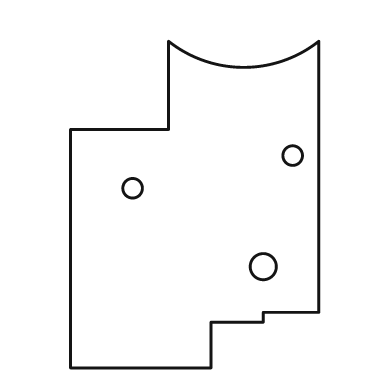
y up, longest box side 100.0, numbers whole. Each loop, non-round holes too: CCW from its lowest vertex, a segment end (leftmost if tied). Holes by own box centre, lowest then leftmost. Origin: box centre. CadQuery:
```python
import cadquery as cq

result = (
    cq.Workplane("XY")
    .moveTo(-38.0, -50.0)
    .lineTo(5.0, -50.0)
    .lineTo(5.0, -36.0)
    .lineTo(21.0, -36.0)
    .lineTo(21.0, -33.0)
    .lineTo(38.0, -33.0)
    .lineTo(38.0, 50.0)
    .threePointArc((15.0, 42.0), (-8.0, 50.0))
    .lineTo(-8.0, 23.0)
    .lineTo(-38.0, 23.0)
    .close()
    .moveTo(21.0, -19.0)
    .circle(4.0)
    .moveTo(-19.0, 5.0)
    .circle(3.0)
    .moveTo(30.0, 15.0)
    .circle(3.0)
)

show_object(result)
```